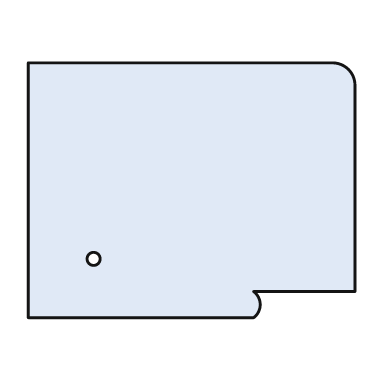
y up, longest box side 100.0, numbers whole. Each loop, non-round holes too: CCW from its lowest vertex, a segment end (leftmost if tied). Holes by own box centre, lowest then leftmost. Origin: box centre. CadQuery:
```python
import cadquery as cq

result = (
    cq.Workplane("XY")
    .moveTo(-50.0, -39.0)
    .lineTo(19.0, -39.0)
    .threePointArc((21.0, -35.0), (19.0, -31.0))
    .lineTo(50.0, -31.0)
    .lineTo(50.0, 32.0)
    .threePointArc((48.0, 37.0), (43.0, 39.0))
    .lineTo(-50.0, 39.0)
    .close()
    .moveTo(-30.0, -21.0)
    .circle(2.0)
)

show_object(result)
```